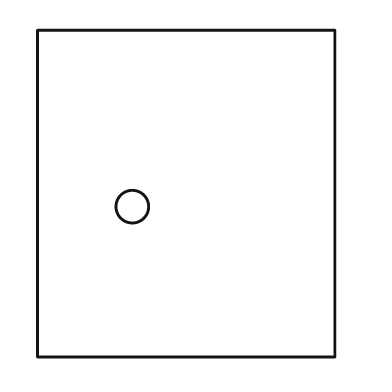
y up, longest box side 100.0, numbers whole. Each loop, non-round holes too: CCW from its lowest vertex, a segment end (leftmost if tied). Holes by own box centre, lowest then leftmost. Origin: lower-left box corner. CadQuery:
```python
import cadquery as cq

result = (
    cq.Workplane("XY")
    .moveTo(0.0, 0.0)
    .lineTo(91.0, 0.0)
    .lineTo(91.0, 100.0)
    .lineTo(0.0, 100.0)
    .close()
    .moveTo(29.0, 46.0)
    .circle(5.0)
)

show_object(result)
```